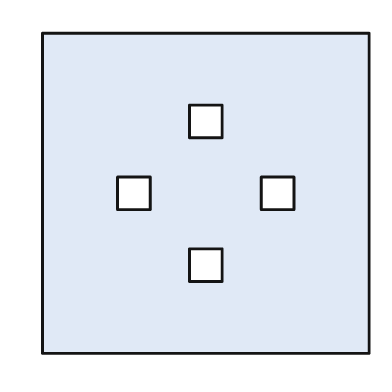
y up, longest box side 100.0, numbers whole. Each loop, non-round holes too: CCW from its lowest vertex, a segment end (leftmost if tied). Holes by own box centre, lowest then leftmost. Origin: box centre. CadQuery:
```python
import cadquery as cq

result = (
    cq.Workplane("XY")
    .moveTo(-50.0, -49.0)
    .lineTo(50.0, -49.0)
    .lineTo(50.0, 49.0)
    .lineTo(-50.0, 49.0)
    .close()
    .moveTo(-5.0, -27.0)
    .lineTo(5.0, -27.0)
    .lineTo(5.0, -17.0)
    .lineTo(-5.0, -17.0)
    .close()
    .moveTo(-27.0, -5.0)
    .lineTo(-17.0, -5.0)
    .lineTo(-17.0, 5.0)
    .lineTo(-27.0, 5.0)
    .close()
    .moveTo(17.0, -5.0)
    .lineTo(27.0, -5.0)
    .lineTo(27.0, 5.0)
    .lineTo(17.0, 5.0)
    .close()
    .moveTo(-5.0, 17.0)
    .lineTo(5.0, 17.0)
    .lineTo(5.0, 27.0)
    .lineTo(-5.0, 27.0)
    .close()
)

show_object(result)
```